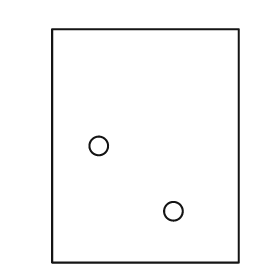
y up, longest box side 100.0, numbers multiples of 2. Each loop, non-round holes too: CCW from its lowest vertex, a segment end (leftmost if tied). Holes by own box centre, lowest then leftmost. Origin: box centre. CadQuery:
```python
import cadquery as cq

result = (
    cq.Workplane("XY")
    .moveTo(-40.0, -50.0)
    .lineTo(40.0, -50.0)
    .lineTo(40.0, 50.0)
    .lineTo(-40.0, 50.0)
    .close()
    .moveTo(12.0, -28.0)
    .circle(4.0)
    .moveTo(-20.0, 0.0)
    .circle(4.0)
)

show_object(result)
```